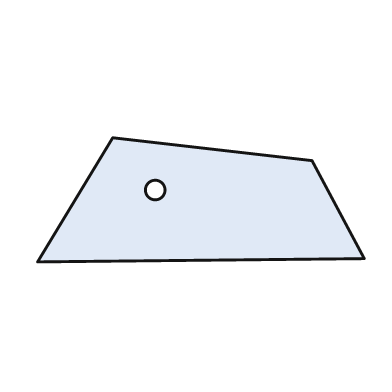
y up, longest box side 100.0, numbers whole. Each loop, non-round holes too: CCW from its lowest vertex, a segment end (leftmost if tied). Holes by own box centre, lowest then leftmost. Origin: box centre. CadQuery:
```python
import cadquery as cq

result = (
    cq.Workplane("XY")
    .moveTo(-50.0, -19.0)
    .lineTo(50.0, -18.0)
    .lineTo(34.0, 12.0)
    .lineTo(-27.0, 19.0)
    .close()
    .moveTo(-14.0, 3.0)
    .circle(3.0)
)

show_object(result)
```